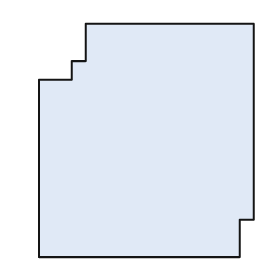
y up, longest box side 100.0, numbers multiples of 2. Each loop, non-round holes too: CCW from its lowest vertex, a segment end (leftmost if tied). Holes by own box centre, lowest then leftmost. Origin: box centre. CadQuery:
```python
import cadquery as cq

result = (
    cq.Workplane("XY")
    .moveTo(-46.0, -50.0)
    .lineTo(40.0, -50.0)
    .lineTo(40.0, -34.0)
    .lineTo(46.0, -34.0)
    .lineTo(46.0, 50.0)
    .lineTo(-26.0, 50.0)
    .lineTo(-26.0, 34.0)
    .lineTo(-32.0, 34.0)
    .lineTo(-32.0, 26.0)
    .lineTo(-46.0, 26.0)
    .close()
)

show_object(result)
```